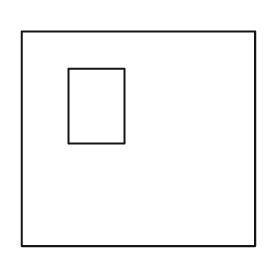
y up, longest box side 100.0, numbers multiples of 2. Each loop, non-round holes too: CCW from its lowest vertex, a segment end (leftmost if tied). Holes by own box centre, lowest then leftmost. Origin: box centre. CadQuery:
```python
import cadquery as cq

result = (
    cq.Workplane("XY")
    .moveTo(-50.0, -46.0)
    .lineTo(50.0, -46.0)
    .lineTo(50.0, 46.0)
    .lineTo(-50.0, 46.0)
    .close()
    .moveTo(-30.0, -2.0)
    .lineTo(-6.0, -2.0)
    .lineTo(-6.0, 30.0)
    .lineTo(-30.0, 30.0)
    .close()
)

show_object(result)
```